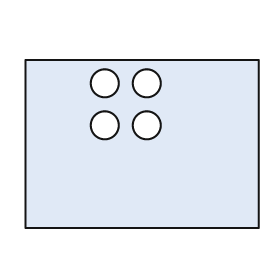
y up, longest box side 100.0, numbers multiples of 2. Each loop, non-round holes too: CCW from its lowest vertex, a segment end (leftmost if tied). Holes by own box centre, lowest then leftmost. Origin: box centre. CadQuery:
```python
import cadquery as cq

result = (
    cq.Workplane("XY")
    .moveTo(-50.0, -36.0)
    .lineTo(50.0, -36.0)
    .lineTo(50.0, 36.0)
    .lineTo(-50.0, 36.0)
    .close()
    .moveTo(-16.0, 8.0)
    .circle(6.0)
    .moveTo(2.0, 8.0)
    .circle(6.0)
    .moveTo(-16.0, 26.0)
    .circle(6.0)
    .moveTo(2.0, 26.0)
    .circle(6.0)
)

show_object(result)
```